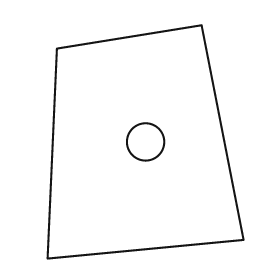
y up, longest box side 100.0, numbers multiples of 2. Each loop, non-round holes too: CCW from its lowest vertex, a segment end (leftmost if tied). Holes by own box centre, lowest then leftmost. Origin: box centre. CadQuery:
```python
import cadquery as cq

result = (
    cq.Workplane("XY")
    .moveTo(-42.0, -50.0)
    .lineTo(42.0, -42.0)
    .lineTo(24.0, 50.0)
    .lineTo(-38.0, 40.0)
    .close()
    .moveTo(0.0, 0.0)
    .circle(8.0)
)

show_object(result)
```